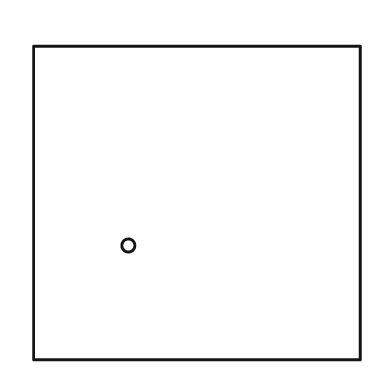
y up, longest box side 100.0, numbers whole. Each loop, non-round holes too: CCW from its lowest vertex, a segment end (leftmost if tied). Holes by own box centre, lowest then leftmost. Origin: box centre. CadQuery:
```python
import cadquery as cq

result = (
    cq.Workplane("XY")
    .moveTo(-50.0, -48.0)
    .lineTo(50.0, -48.0)
    .lineTo(50.0, 48.0)
    .lineTo(-50.0, 48.0)
    .close()
    .moveTo(-21.0, -13.0)
    .circle(2.0)
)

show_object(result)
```